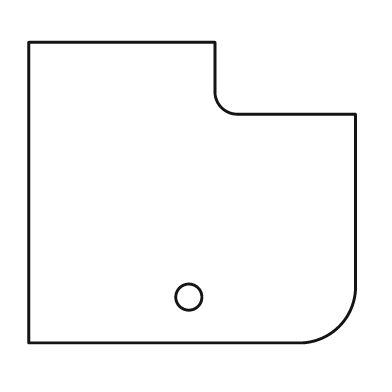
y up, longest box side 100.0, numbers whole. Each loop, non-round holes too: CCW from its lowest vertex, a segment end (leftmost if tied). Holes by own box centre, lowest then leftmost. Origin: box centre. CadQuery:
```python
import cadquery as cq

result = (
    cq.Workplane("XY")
    .moveTo(-50.0, -46.0)
    .lineTo(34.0, -46.0)
    .threePointArc((45.0, -41.0), (50.0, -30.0))
    .lineTo(50.0, 24.0)
    .lineTo(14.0, 24.0)
    .threePointArc((9.0, 26.0), (7.0, 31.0))
    .lineTo(7.0, 46.0)
    .lineTo(-50.0, 46.0)
    .close()
    .moveTo(-1.0, -32.0)
    .circle(4.0)
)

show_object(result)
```